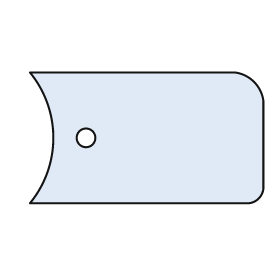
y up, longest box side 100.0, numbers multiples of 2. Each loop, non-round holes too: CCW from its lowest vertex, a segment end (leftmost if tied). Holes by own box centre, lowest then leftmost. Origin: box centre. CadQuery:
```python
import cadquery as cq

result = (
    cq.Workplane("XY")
    .moveTo(-50.0, -28.0)
    .lineTo(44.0, -28.0)
    .threePointArc((48.0, -26.0), (50.0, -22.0))
    .lineTo(50.0, 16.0)
    .threePointArc((46.0, 24.0), (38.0, 28.0))
    .lineTo(-50.0, 28.0)
    .threePointArc((-40.0, 0.0), (-50.0, -28.0))
    .close()
    .moveTo(-26.0, 0.0)
    .circle(4.0)
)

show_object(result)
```